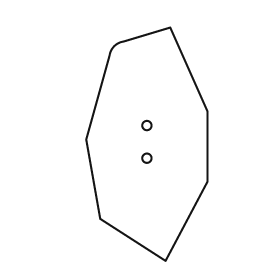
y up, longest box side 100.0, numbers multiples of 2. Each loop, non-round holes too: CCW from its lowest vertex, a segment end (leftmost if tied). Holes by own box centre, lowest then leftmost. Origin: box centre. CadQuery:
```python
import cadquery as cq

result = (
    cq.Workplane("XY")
    .moveTo(8.0, -50.0)
    .lineTo(26.0, -16.0)
    .lineTo(26.0, 14.0)
    .lineTo(10.0, 50.0)
    .lineTo(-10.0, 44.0)
    .threePointArc((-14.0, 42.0), (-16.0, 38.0))
    .lineTo(-26.0, 2.0)
    .lineTo(-20.0, -32.0)
    .close()
    .moveTo(0.0, -6.0)
    .circle(2.0)
    .moveTo(0.0, 8.0)
    .circle(2.0)
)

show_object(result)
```